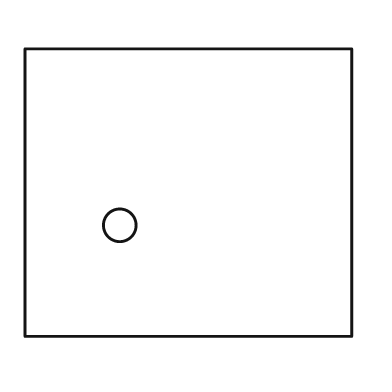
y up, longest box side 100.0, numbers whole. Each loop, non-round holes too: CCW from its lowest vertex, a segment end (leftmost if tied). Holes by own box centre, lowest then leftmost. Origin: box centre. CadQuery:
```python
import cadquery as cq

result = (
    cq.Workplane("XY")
    .moveTo(-50.0, -44.0)
    .lineTo(50.0, -44.0)
    .lineTo(50.0, 44.0)
    .lineTo(-50.0, 44.0)
    .close()
    .moveTo(-21.0, -10.0)
    .circle(5.0)
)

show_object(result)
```